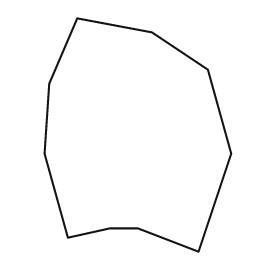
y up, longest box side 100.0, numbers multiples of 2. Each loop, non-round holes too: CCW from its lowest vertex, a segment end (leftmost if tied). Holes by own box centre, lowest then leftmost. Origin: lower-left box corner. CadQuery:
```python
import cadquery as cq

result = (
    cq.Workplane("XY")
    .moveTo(66.0, 0.0)
    .lineTo(80.0, 42.0)
    .lineTo(70.0, 78.0)
    .lineTo(46.0, 94.0)
    .lineTo(14.0, 100.0)
    .lineTo(2.0, 72.0)
    .lineTo(0.0, 42.0)
    .lineTo(10.0, 6.0)
    .lineTo(28.0, 10.0)
    .lineTo(40.0, 10.0)
    .close()
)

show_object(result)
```